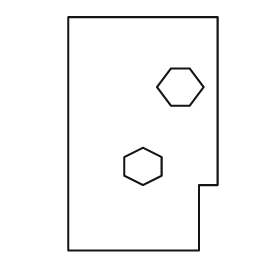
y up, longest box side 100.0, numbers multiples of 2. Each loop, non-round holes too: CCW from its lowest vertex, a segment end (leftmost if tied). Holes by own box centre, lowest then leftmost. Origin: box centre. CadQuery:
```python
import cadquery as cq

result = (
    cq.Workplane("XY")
    .moveTo(-32.0, -50.0)
    .lineTo(24.0, -50.0)
    .lineTo(24.0, -22.0)
    .lineTo(32.0, -22.0)
    .lineTo(32.0, 50.0)
    .lineTo(-32.0, 50.0)
    .close()
    .moveTo(0.0, -22.0)
    .lineTo(8.0, -18.0)
    .lineTo(8.0, -10.0)
    .lineTo(0.0, -6.0)
    .lineTo(-8.0, -10.0)
    .lineTo(-8.0, -18.0)
    .close()
    .moveTo(12.0, 12.0)
    .lineTo(20.0, 12.0)
    .lineTo(26.0, 20.0)
    .lineTo(20.0, 28.0)
    .lineTo(12.0, 28.0)
    .lineTo(6.0, 20.0)
    .close()
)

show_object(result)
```